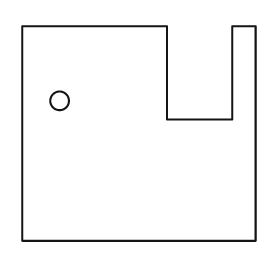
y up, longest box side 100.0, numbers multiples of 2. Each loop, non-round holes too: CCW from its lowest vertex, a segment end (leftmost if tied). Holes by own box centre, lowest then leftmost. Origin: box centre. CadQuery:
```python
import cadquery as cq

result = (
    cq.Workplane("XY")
    .moveTo(-50.0, -46.0)
    .lineTo(50.0, -46.0)
    .lineTo(50.0, 46.0)
    .lineTo(40.0, 46.0)
    .lineTo(40.0, 6.0)
    .lineTo(12.0, 6.0)
    .lineTo(12.0, 46.0)
    .lineTo(-50.0, 46.0)
    .close()
    .moveTo(-34.0, 14.0)
    .circle(4.0)
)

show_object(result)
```